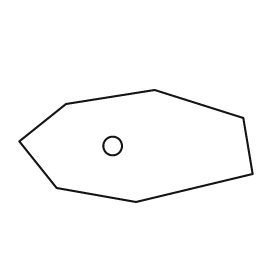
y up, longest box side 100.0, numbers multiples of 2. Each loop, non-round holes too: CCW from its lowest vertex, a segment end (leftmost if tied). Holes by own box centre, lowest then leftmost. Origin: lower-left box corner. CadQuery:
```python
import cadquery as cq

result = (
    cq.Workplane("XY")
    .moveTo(50.0, 0.0)
    .lineTo(100.0, 12.0)
    .lineTo(96.0, 36.0)
    .lineTo(58.0, 48.0)
    .lineTo(20.0, 42.0)
    .lineTo(0.0, 26.0)
    .lineTo(16.0, 6.0)
    .close()
    .moveTo(40.0, 24.0)
    .circle(4.0)
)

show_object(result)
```